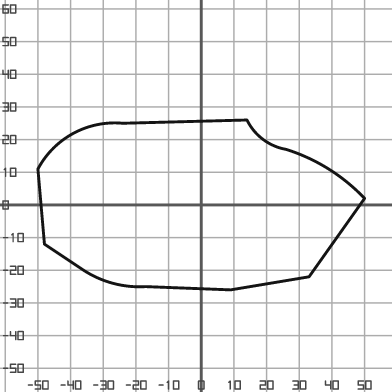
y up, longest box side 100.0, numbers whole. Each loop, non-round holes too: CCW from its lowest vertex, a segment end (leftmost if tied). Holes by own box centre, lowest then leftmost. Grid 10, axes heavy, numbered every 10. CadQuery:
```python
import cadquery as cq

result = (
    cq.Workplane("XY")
    .moveTo(9.0, -26.0)
    .lineTo(33.0, -22.0)
    .lineTo(50.0, 2.0)
    .threePointArc((39.0, 11.0), (26.0, 17.0))
    .threePointArc((19.0, 20.0), (14.0, 26.0))
    .lineTo(-24.0, 25.0)
    .threePointArc((-39.0, 22.0), (-50.0, 11.0))
    .lineTo(-48.0, -12.0)
    .lineTo(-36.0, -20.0)
    .threePointArc((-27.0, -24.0), (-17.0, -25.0))
    .close()
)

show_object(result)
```